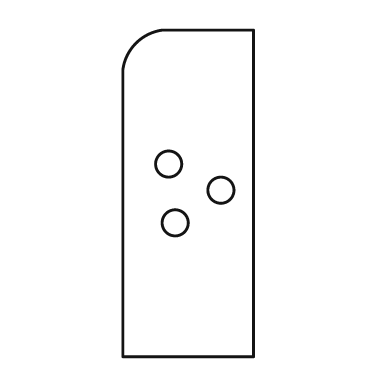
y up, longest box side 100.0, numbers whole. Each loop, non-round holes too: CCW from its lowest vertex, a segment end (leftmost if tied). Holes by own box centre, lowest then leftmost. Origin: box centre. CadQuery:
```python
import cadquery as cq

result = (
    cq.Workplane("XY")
    .moveTo(-20.0, -50.0)
    .lineTo(20.0, -50.0)
    .lineTo(20.0, 50.0)
    .lineTo(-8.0, 50.0)
    .threePointArc((-16.0, 46.0), (-20.0, 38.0))
    .close()
    .moveTo(-4.0, -9.0)
    .circle(4.0)
    .moveTo(10.0, 1.0)
    .circle(4.0)
    .moveTo(-6.0, 9.0)
    .circle(4.0)
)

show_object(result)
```